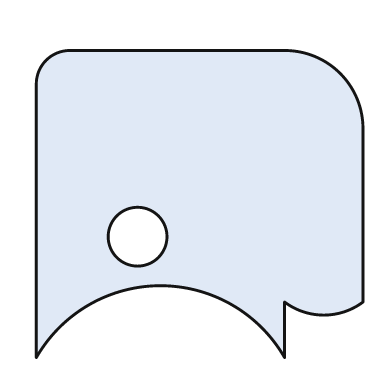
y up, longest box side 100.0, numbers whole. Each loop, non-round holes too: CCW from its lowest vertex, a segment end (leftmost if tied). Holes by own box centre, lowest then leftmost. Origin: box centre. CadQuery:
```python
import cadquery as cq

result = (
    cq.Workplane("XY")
    .moveTo(-50.0, -47.0)
    .threePointArc((-12.0, -25.0), (26.0, -47.0))
    .lineTo(26.0, -30.0)
    .threePointArc((38.0, -34.0), (50.0, -30.0))
    .lineTo(50.0, 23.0)
    .threePointArc((43.0, 40.0), (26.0, 47.0))
    .lineTo(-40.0, 47.0)
    .threePointArc((-47.0, 44.0), (-50.0, 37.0))
    .close()
    .moveTo(-19.0, -10.0)
    .circle(9.0)
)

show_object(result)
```